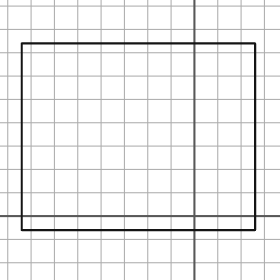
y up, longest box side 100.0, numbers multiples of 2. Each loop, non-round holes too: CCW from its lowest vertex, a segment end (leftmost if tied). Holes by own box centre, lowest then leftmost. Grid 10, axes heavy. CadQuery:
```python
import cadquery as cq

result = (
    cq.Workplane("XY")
    .moveTo(-74.0, -6.0)
    .lineTo(26.0, -6.0)
    .lineTo(26.0, 74.0)
    .lineTo(-74.0, 74.0)
    .close()
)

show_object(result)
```